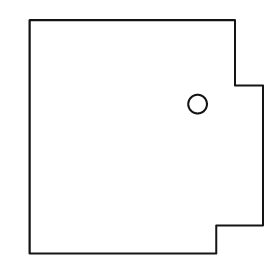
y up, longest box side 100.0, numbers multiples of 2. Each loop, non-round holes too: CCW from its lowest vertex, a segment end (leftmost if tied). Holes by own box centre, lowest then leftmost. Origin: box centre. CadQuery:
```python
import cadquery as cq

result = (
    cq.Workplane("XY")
    .moveTo(-50.0, -50.0)
    .lineTo(30.0, -50.0)
    .lineTo(30.0, -38.0)
    .lineTo(50.0, -38.0)
    .lineTo(50.0, 22.0)
    .lineTo(38.0, 22.0)
    .lineTo(38.0, 50.0)
    .lineTo(-50.0, 50.0)
    .close()
    .moveTo(22.0, 14.0)
    .circle(4.0)
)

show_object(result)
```